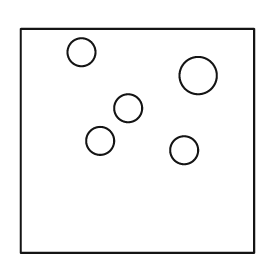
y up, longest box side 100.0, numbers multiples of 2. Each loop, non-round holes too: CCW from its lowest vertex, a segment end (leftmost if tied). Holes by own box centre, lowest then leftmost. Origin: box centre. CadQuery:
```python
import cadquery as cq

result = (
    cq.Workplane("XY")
    .moveTo(-50.0, -48.0)
    .lineTo(50.0, -48.0)
    .lineTo(50.0, 48.0)
    .lineTo(-50.0, 48.0)
    .close()
    .moveTo(20.0, -4.0)
    .circle(6.0)
    .moveTo(-16.0, 0.0)
    .circle(6.0)
    .moveTo(-4.0, 14.0)
    .circle(6.0)
    .moveTo(26.0, 28.0)
    .circle(8.0)
    .moveTo(-24.0, 38.0)
    .circle(6.0)
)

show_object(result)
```